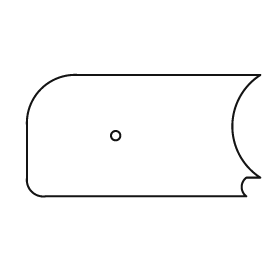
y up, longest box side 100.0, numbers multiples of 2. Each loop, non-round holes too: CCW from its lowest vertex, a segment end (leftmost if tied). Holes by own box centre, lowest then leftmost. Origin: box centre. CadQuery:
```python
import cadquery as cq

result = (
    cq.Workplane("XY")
    .moveTo(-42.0, -26.0)
    .lineTo(44.0, -26.0)
    .threePointArc((42.0, -22.0), (44.0, -18.0))
    .lineTo(50.0, -18.0)
    .threePointArc((38.0, 4.0), (50.0, 26.0))
    .lineTo(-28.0, 26.0)
    .threePointArc((-44.0, 20.0), (-50.0, 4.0))
    .lineTo(-50.0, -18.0)
    .threePointArc((-48.0, -24.0), (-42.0, -26.0))
    .close()
    .moveTo(-12.0, 0.0)
    .circle(2.0)
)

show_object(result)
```